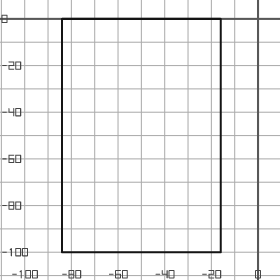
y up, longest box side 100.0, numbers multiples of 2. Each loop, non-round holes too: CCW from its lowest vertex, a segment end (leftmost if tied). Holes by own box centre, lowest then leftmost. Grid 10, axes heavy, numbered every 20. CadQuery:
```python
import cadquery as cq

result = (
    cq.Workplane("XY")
    .moveTo(-84.0, -100.0)
    .lineTo(-16.0, -100.0)
    .lineTo(-16.0, 0.0)
    .lineTo(-84.0, 0.0)
    .close()
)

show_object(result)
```